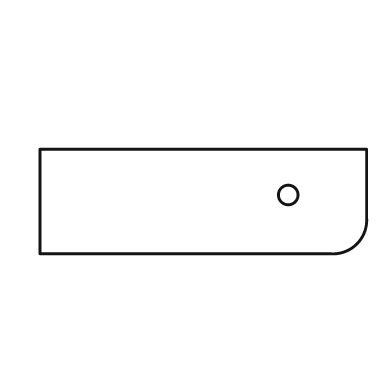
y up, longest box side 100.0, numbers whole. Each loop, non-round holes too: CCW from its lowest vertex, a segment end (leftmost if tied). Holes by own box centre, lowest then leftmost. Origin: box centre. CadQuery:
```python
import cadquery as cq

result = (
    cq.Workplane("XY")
    .moveTo(-50.0, -16.0)
    .lineTo(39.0, -16.0)
    .threePointArc((47.0, -13.0), (50.0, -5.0))
    .lineTo(50.0, 16.0)
    .lineTo(-50.0, 16.0)
    .close()
    .moveTo(26.0, 2.0)
    .circle(3.0)
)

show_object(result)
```